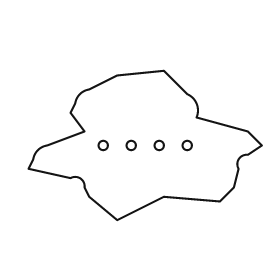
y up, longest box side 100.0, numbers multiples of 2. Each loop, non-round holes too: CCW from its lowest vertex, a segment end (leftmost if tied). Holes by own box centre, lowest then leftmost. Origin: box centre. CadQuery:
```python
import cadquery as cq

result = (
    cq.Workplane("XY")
    .moveTo(-12.0, -32.0)
    .lineTo(8.0, -22.0)
    .lineTo(32.0, -24.0)
    .lineTo(38.0, -18.0)
    .lineTo(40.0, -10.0)
    .threePointArc((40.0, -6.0), (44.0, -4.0))
    .lineTo(50.0, 0.0)
    .lineTo(44.0, 6.0)
    .lineTo(22.0, 12.0)
    .threePointArc((22.0, 18.0), (18.0, 22.0))
    .lineTo(8.0, 32.0)
    .lineTo(-12.0, 30.0)
    .lineTo(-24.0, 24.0)
    .threePointArc((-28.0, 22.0), (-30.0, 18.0))
    .lineTo(-32.0, 14.0)
    .lineTo(-26.0, 6.0)
    .lineTo(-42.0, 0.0)
    .threePointArc((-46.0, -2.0), (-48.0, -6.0))
    .lineTo(-50.0, -10.0)
    .lineTo(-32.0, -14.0)
    .threePointArc((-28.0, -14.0), (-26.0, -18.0))
    .lineTo(-24.0, -22.0)
    .close()
    .moveTo(-18.0, 0.0)
    .circle(2.0)
    .moveTo(-6.0, 0.0)
    .circle(2.0)
    .moveTo(6.0, 0.0)
    .circle(2.0)
    .moveTo(18.0, 0.0)
    .circle(2.0)
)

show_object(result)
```